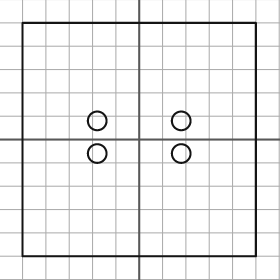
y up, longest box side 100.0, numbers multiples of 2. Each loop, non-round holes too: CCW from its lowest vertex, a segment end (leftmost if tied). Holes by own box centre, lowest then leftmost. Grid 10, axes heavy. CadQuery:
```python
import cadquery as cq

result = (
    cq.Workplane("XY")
    .moveTo(-50.0, -50.0)
    .lineTo(50.0, -50.0)
    .lineTo(50.0, 50.0)
    .lineTo(-50.0, 50.0)
    .close()
    .moveTo(-18.0, -6.0)
    .circle(4.0)
    .moveTo(18.0, -6.0)
    .circle(4.0)
    .moveTo(-18.0, 8.0)
    .circle(4.0)
    .moveTo(18.0, 8.0)
    .circle(4.0)
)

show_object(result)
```